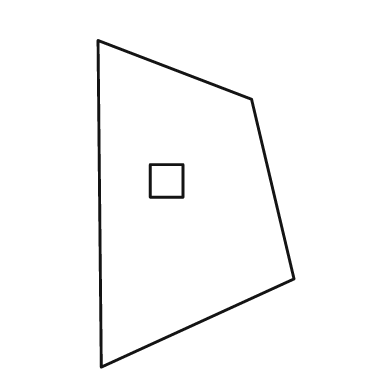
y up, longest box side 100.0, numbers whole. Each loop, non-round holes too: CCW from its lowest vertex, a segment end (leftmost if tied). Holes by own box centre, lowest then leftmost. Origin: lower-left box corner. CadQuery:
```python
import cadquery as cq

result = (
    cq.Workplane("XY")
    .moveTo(1.0, 0.0)
    .lineTo(60.0, 27.0)
    .lineTo(47.0, 82.0)
    .lineTo(0.0, 100.0)
    .close()
    .moveTo(16.0, 52.0)
    .lineTo(26.0, 52.0)
    .lineTo(26.0, 62.0)
    .lineTo(16.0, 62.0)
    .close()
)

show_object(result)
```